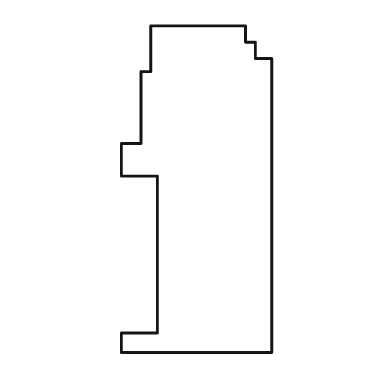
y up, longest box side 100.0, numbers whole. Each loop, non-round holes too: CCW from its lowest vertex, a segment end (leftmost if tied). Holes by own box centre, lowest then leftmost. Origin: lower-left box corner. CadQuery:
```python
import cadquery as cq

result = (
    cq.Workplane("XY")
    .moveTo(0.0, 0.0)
    .lineTo(46.0, 0.0)
    .lineTo(46.0, 90.0)
    .lineTo(41.0, 90.0)
    .lineTo(41.0, 95.0)
    .lineTo(38.0, 95.0)
    .lineTo(38.0, 100.0)
    .lineTo(9.0, 100.0)
    .lineTo(9.0, 86.0)
    .lineTo(6.0, 86.0)
    .lineTo(6.0, 64.0)
    .lineTo(0.0, 64.0)
    .lineTo(0.0, 54.0)
    .lineTo(11.0, 54.0)
    .lineTo(11.0, 6.0)
    .lineTo(0.0, 6.0)
    .close()
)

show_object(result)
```